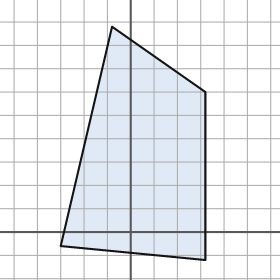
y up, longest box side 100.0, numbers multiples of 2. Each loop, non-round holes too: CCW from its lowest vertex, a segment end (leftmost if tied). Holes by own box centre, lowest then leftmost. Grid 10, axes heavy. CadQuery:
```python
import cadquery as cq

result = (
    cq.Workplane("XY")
    .moveTo(32.0, -12.0)
    .lineTo(32.0, 60.0)
    .lineTo(-8.0, 88.0)
    .lineTo(-30.0, -6.0)
    .close()
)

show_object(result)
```